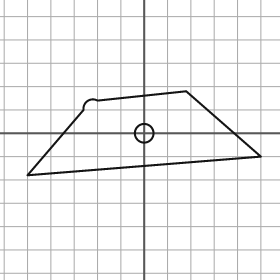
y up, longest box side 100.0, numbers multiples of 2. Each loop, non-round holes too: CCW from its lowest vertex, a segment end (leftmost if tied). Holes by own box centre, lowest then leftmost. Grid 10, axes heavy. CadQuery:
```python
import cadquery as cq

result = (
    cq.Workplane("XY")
    .moveTo(-50.0, -18.0)
    .lineTo(50.0, -10.0)
    .lineTo(18.0, 18.0)
    .lineTo(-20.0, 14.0)
    .threePointArc((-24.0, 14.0), (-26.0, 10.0))
    .close()
    .moveTo(0.0, 0.0)
    .circle(4.0)
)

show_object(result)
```